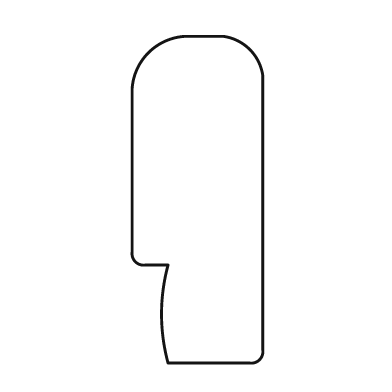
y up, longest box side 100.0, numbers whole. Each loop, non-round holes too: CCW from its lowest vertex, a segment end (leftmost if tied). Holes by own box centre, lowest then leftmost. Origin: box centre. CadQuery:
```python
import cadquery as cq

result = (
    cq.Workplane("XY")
    .moveTo(-9.0, -50.0)
    .lineTo(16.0, -50.0)
    .threePointArc((19.0, -49.0), (20.0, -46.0))
    .lineTo(20.0, 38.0)
    .threePointArc((16.0, 46.0), (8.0, 50.0))
    .lineTo(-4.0, 50.0)
    .threePointArc((-15.0, 45.0), (-20.0, 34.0))
    .lineTo(-20.0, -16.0)
    .threePointArc((-19.0, -19.0), (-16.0, -20.0))
    .lineTo(-9.0, -20.0)
    .threePointArc((-11.0, -35.0), (-9.0, -50.0))
    .close()
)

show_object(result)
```